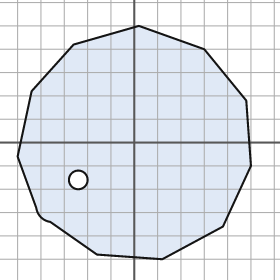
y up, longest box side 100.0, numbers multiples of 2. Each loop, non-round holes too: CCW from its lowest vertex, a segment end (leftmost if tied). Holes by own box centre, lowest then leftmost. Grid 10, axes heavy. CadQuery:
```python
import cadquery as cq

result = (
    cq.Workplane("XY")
    .moveTo(12.0, -50.0)
    .lineTo(38.0, -36.0)
    .lineTo(50.0, -10.0)
    .lineTo(48.0, 18.0)
    .lineTo(30.0, 40.0)
    .lineTo(2.0, 50.0)
    .lineTo(-26.0, 42.0)
    .lineTo(-44.0, 22.0)
    .lineTo(-50.0, -6.0)
    .lineTo(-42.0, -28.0)
    .threePointArc((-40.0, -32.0), (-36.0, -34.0))
    .lineTo(-16.0, -48.0)
    .close()
    .moveTo(-24.0, -16.0)
    .circle(4.0)
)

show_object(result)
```